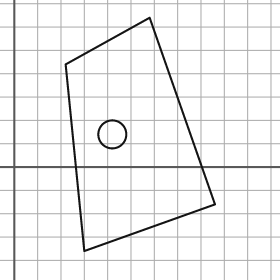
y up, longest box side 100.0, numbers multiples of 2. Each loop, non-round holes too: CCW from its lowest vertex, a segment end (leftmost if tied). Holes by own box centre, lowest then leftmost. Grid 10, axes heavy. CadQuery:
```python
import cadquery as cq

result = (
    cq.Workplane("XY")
    .moveTo(30.0, -36.0)
    .lineTo(86.0, -16.0)
    .lineTo(58.0, 64.0)
    .lineTo(22.0, 44.0)
    .close()
    .moveTo(42.0, 14.0)
    .circle(6.0)
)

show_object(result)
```